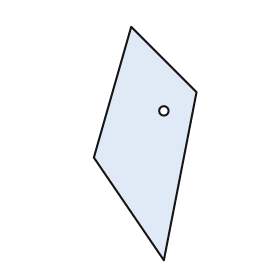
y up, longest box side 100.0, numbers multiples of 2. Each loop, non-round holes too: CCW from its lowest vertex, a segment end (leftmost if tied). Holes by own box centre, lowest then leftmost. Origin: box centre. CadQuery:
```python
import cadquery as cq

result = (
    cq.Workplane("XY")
    .moveTo(8.0, -50.0)
    .lineTo(22.0, 22.0)
    .lineTo(-6.0, 50.0)
    .lineTo(-22.0, -6.0)
    .close()
    .moveTo(8.0, 14.0)
    .circle(2.0)
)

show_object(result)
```